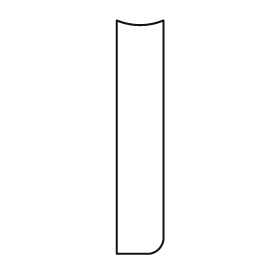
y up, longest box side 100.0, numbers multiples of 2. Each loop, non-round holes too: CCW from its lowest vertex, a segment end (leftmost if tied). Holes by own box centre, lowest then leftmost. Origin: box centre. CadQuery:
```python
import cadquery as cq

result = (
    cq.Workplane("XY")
    .moveTo(-10.0, -50.0)
    .lineTo(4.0, -50.0)
    .threePointArc((8.0, -48.0), (10.0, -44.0))
    .lineTo(10.0, 50.0)
    .threePointArc((0.0, 48.0), (-10.0, 50.0))
    .close()
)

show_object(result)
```